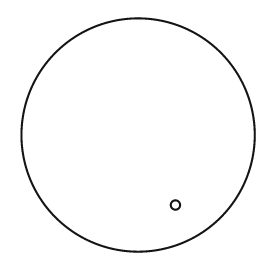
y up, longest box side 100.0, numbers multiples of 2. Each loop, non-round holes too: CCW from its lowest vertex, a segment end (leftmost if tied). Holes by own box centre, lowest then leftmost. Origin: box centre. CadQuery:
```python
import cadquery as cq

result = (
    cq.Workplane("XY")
    .moveTo(0.0, 0.0)
    .circle(50.0)
    .moveTo(16.0, -30.0)
    .circle(2.0)
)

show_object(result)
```